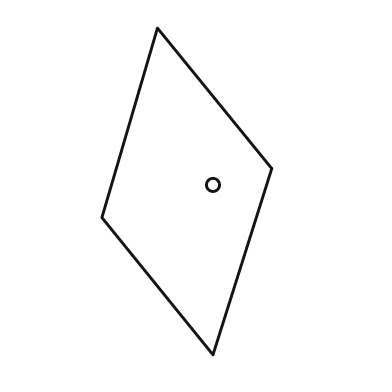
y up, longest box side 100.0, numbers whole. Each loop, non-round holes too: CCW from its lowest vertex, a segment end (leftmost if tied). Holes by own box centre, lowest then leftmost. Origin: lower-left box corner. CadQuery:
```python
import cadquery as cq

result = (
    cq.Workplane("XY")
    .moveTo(34.0, 0.0)
    .lineTo(52.0, 57.0)
    .lineTo(17.0, 100.0)
    .lineTo(0.0, 42.0)
    .close()
    .moveTo(34.0, 52.0)
    .circle(2.0)
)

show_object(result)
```